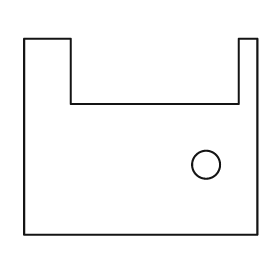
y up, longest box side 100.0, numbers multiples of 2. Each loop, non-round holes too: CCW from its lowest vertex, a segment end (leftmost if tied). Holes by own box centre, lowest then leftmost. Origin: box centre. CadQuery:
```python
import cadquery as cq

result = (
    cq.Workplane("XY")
    .moveTo(-50.0, -42.0)
    .lineTo(50.0, -42.0)
    .lineTo(50.0, 42.0)
    .lineTo(42.0, 42.0)
    .lineTo(42.0, 14.0)
    .lineTo(-30.0, 14.0)
    .lineTo(-30.0, 42.0)
    .lineTo(-50.0, 42.0)
    .close()
    .moveTo(28.0, -12.0)
    .circle(6.0)
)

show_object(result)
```